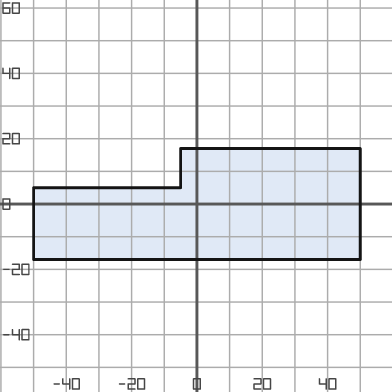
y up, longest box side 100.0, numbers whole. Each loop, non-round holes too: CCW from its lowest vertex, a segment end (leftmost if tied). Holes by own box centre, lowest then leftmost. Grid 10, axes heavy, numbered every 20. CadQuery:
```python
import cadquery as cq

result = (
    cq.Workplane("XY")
    .moveTo(-50.0, -17.0)
    .lineTo(50.0, -17.0)
    .lineTo(50.0, 17.0)
    .lineTo(-5.0, 17.0)
    .lineTo(-5.0, 5.0)
    .lineTo(-50.0, 5.0)
    .close()
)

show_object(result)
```